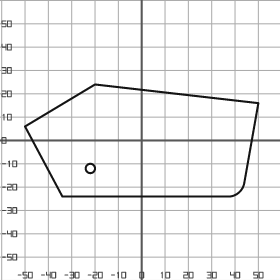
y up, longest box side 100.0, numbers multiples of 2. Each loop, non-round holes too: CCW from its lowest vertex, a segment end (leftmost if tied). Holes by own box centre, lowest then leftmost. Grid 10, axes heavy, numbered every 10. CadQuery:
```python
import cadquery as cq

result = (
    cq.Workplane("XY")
    .moveTo(-34.0, -24.0)
    .lineTo(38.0, -24.0)
    .threePointArc((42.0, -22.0), (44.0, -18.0))
    .lineTo(50.0, 16.0)
    .lineTo(-20.0, 24.0)
    .lineTo(-50.0, 6.0)
    .close()
    .moveTo(-22.0, -12.0)
    .circle(2.0)
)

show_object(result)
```